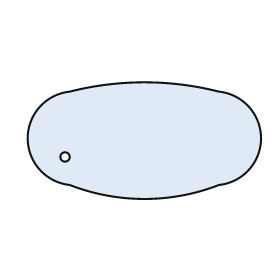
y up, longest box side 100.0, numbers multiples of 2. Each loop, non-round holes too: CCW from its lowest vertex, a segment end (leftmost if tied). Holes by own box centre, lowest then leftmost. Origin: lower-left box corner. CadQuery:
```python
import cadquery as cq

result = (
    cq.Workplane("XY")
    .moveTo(18.0, 6.0)
    .threePointArc((50.0, 0.0), (82.0, 6.0))
    .threePointArc((100.0, 26.0), (82.0, 46.0))
    .threePointArc((50.0, 50.0), (18.0, 46.0))
    .threePointArc((0.0, 26.0), (18.0, 6.0))
    .close()
    .moveTo(16.0, 18.0)
    .circle(2.0)
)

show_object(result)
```